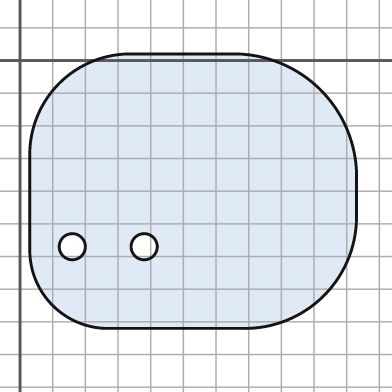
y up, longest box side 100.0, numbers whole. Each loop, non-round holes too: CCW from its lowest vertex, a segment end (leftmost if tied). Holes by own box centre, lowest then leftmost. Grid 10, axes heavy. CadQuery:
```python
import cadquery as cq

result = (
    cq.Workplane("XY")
    .moveTo(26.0, -82.0)
    .lineTo(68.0, -82.0)
    .threePointArc((93.0, -72.0), (103.0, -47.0))
    .lineTo(103.0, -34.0)
    .threePointArc((92.0, -9.0), (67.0, 2.0))
    .lineTo(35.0, 2.0)
    .threePointArc((12.0, -7.0), (3.0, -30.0))
    .lineTo(3.0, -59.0)
    .threePointArc((10.0, -75.0), (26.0, -82.0))
    .close()
    .moveTo(16.0, -57.0)
    .circle(4.0)
    .moveTo(38.0, -57.0)
    .circle(4.0)
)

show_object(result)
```